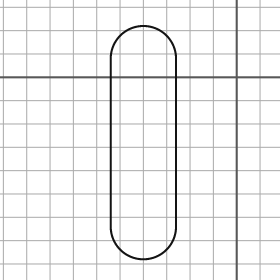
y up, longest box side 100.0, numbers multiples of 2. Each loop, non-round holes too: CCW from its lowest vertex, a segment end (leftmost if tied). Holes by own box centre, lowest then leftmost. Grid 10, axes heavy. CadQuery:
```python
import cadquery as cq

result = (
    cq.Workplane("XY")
    .moveTo(-54.0, -64.0)
    .threePointArc((-40.0, -78.0), (-26.0, -64.0))
    .lineTo(-26.0, 8.0)
    .threePointArc((-40.0, 22.0), (-54.0, 8.0))
    .close()
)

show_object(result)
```